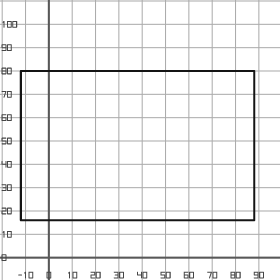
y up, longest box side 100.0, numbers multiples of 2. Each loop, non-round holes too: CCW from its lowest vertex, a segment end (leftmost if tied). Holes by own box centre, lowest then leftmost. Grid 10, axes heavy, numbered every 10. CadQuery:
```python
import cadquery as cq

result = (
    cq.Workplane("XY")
    .moveTo(-12.0, 16.0)
    .lineTo(88.0, 16.0)
    .lineTo(88.0, 80.0)
    .lineTo(-12.0, 80.0)
    .close()
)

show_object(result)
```